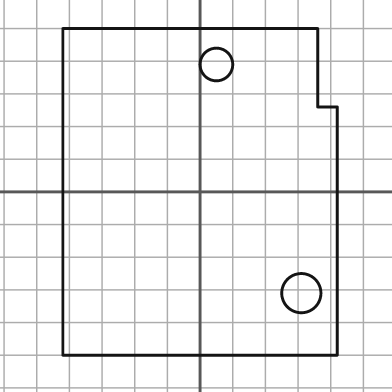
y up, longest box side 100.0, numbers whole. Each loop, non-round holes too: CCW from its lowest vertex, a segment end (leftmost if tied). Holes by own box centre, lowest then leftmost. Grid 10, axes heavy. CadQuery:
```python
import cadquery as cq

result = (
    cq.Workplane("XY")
    .moveTo(-42.0, -50.0)
    .lineTo(42.0, -50.0)
    .lineTo(42.0, 26.0)
    .lineTo(36.0, 26.0)
    .lineTo(36.0, 50.0)
    .lineTo(-42.0, 50.0)
    .close()
    .moveTo(31.0, -31.0)
    .circle(6.0)
    .moveTo(5.0, 39.0)
    .circle(5.0)
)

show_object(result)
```